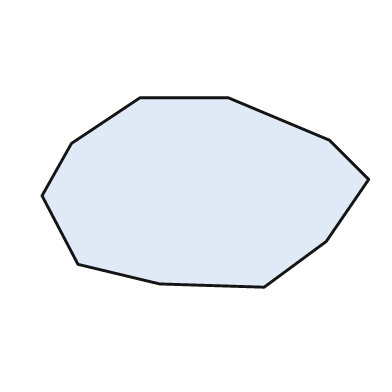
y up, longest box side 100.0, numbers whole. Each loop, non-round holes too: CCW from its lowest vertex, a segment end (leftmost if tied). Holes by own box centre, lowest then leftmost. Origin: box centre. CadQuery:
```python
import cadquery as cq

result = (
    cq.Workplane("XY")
    .moveTo(18.0, -29.0)
    .lineTo(37.0, -15.0)
    .lineTo(50.0, 4.0)
    .lineTo(38.0, 16.0)
    .lineTo(7.0, 29.0)
    .lineTo(-20.0, 29.0)
    .lineTo(-41.0, 15.0)
    .lineTo(-50.0, -1.0)
    .lineTo(-39.0, -22.0)
    .lineTo(-14.0, -28.0)
    .close()
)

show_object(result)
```